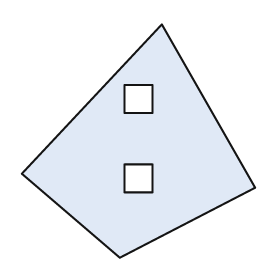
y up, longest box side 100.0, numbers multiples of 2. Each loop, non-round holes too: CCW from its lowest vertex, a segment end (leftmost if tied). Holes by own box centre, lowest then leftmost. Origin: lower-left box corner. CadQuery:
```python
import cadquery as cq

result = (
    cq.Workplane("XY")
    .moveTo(42.0, 0.0)
    .lineTo(100.0, 30.0)
    .lineTo(60.0, 100.0)
    .lineTo(0.0, 36.0)
    .close()
    .moveTo(44.0, 28.0)
    .lineTo(56.0, 28.0)
    .lineTo(56.0, 40.0)
    .lineTo(44.0, 40.0)
    .close()
    .moveTo(44.0, 62.0)
    .lineTo(56.0, 62.0)
    .lineTo(56.0, 74.0)
    .lineTo(44.0, 74.0)
    .close()
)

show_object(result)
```